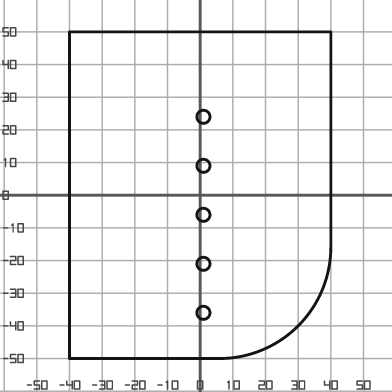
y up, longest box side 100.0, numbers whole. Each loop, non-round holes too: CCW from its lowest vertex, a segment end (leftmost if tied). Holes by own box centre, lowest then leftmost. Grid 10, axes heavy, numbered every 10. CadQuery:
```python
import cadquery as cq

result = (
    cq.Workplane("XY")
    .moveTo(-40.0, -50.0)
    .lineTo(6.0, -50.0)
    .threePointArc((30.0, -40.0), (40.0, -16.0))
    .lineTo(40.0, 50.0)
    .lineTo(-40.0, 50.0)
    .close()
    .moveTo(1.0, -36.0)
    .circle(2.0)
    .moveTo(1.0, -21.0)
    .circle(2.0)
    .moveTo(1.0, -6.0)
    .circle(2.0)
    .moveTo(1.0, 9.0)
    .circle(2.0)
    .moveTo(1.0, 24.0)
    .circle(2.0)
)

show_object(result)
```